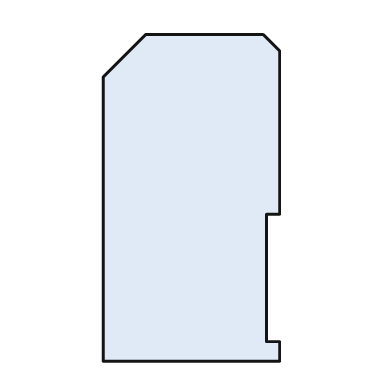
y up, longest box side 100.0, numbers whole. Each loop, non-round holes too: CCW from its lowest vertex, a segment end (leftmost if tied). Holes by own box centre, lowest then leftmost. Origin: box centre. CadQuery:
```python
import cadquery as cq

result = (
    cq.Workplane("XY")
    .moveTo(-27.0, -50.0)
    .lineTo(27.0, -50.0)
    .lineTo(27.0, -44.0)
    .lineTo(23.0, -44.0)
    .lineTo(23.0, -5.0)
    .lineTo(27.0, -5.0)
    .lineTo(27.0, 45.0)
    .lineTo(22.0, 50.0)
    .lineTo(-14.0, 50.0)
    .lineTo(-27.0, 37.0)
    .close()
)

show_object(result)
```